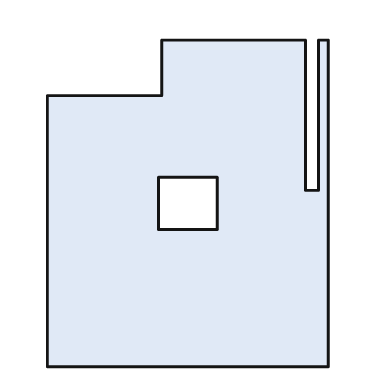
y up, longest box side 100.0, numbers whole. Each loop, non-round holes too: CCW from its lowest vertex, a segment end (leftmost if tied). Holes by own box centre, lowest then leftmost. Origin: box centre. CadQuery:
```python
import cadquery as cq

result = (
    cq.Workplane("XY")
    .moveTo(-43.0, -50.0)
    .lineTo(43.0, -50.0)
    .lineTo(43.0, 50.0)
    .lineTo(40.0, 50.0)
    .lineTo(40.0, 4.0)
    .lineTo(36.0, 4.0)
    .lineTo(36.0, 50.0)
    .lineTo(-8.0, 50.0)
    .lineTo(-8.0, 33.0)
    .lineTo(-43.0, 33.0)
    .close()
    .moveTo(-9.0, -8.0)
    .lineTo(9.0, -8.0)
    .lineTo(9.0, 8.0)
    .lineTo(-9.0, 8.0)
    .close()
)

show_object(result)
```